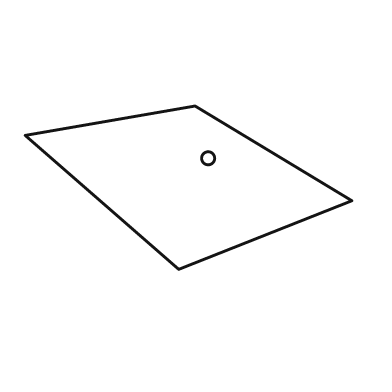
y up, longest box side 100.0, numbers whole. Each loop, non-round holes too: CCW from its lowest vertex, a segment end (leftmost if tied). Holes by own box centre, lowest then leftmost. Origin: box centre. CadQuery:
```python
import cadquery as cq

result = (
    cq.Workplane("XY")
    .moveTo(-3.0, -25.0)
    .lineTo(50.0, -4.0)
    .lineTo(2.0, 25.0)
    .lineTo(-50.0, 16.0)
    .close()
    .moveTo(6.0, 9.0)
    .circle(2.0)
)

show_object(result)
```